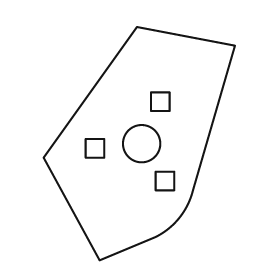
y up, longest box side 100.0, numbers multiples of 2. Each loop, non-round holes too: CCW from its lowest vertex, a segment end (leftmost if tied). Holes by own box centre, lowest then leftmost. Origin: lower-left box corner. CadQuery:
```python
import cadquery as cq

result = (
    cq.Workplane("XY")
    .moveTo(24.0, 0.0)
    .lineTo(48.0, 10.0)
    .threePointArc((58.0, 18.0), (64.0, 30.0))
    .lineTo(82.0, 92.0)
    .lineTo(40.0, 100.0)
    .lineTo(0.0, 44.0)
    .close()
    .moveTo(48.0, 30.0)
    .lineTo(56.0, 30.0)
    .lineTo(56.0, 38.0)
    .lineTo(48.0, 38.0)
    .close()
    .moveTo(18.0, 44.0)
    .lineTo(26.0, 44.0)
    .lineTo(26.0, 52.0)
    .lineTo(18.0, 52.0)
    .close()
    .moveTo(42.0, 50.0)
    .circle(8.0)
    .moveTo(46.0, 64.0)
    .lineTo(54.0, 64.0)
    .lineTo(54.0, 72.0)
    .lineTo(46.0, 72.0)
    .close()
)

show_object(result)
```